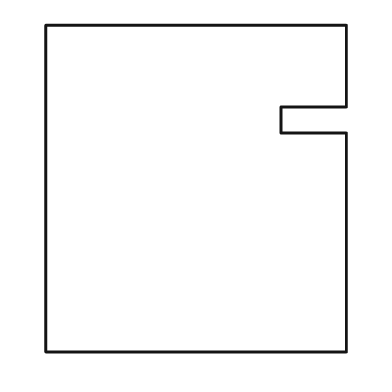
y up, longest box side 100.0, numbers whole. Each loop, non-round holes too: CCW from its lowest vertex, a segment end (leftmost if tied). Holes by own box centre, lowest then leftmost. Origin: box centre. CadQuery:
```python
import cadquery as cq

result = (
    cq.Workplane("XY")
    .moveTo(-46.0, -50.0)
    .lineTo(46.0, -50.0)
    .lineTo(46.0, 17.0)
    .lineTo(26.0, 17.0)
    .lineTo(26.0, 25.0)
    .lineTo(46.0, 25.0)
    .lineTo(46.0, 50.0)
    .lineTo(-46.0, 50.0)
    .close()
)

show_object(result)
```